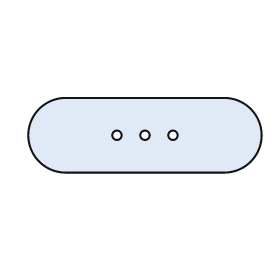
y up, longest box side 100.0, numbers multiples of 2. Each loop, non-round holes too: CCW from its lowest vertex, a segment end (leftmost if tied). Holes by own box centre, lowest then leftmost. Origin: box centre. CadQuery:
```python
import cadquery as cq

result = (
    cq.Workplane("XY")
    .moveTo(-34.0, -16.0)
    .lineTo(34.0, -16.0)
    .threePointArc((50.0, 0.0), (34.0, 16.0))
    .lineTo(-34.0, 16.0)
    .threePointArc((-50.0, 0.0), (-34.0, -16.0))
    .close()
    .moveTo(-12.0, 0.0)
    .circle(2.0)
    .moveTo(0.0, 0.0)
    .circle(2.0)
    .moveTo(12.0, 0.0)
    .circle(2.0)
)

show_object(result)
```